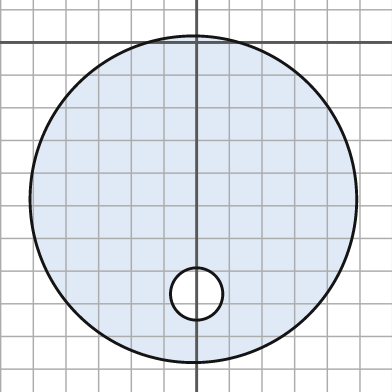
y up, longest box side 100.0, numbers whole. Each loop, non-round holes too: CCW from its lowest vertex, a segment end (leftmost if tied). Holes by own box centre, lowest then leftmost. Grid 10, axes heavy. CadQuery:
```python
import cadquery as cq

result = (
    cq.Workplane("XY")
    .moveTo(-1.0, -48.0)
    .circle(50.0)
    .moveTo(0.0, -77.0)
    .circle(8.0)
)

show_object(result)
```